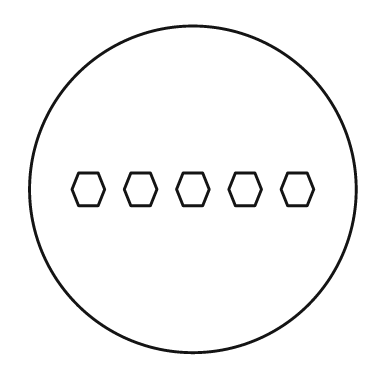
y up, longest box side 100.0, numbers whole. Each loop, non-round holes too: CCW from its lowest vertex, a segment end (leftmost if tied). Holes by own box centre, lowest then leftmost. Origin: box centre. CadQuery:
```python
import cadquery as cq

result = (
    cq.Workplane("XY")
    .moveTo(0.0, 0.0)
    .circle(50.0)
    .moveTo(-35.0, -5.0)
    .lineTo(-29.0, -5.0)
    .lineTo(-27.0, 0.0)
    .lineTo(-29.0, 5.0)
    .lineTo(-35.0, 5.0)
    .lineTo(-37.0, 0.0)
    .close()
    .moveTo(-19.0, -5.0)
    .lineTo(-13.0, -5.0)
    .lineTo(-11.0, 0.0)
    .lineTo(-13.0, 5.0)
    .lineTo(-19.0, 5.0)
    .lineTo(-21.0, 0.0)
    .close()
    .moveTo(-3.0, -5.0)
    .lineTo(3.0, -5.0)
    .lineTo(5.0, 0.0)
    .lineTo(3.0, 5.0)
    .lineTo(-3.0, 5.0)
    .lineTo(-5.0, 0.0)
    .close()
    .moveTo(13.0, -5.0)
    .lineTo(19.0, -5.0)
    .lineTo(21.0, 0.0)
    .lineTo(19.0, 5.0)
    .lineTo(13.0, 5.0)
    .lineTo(11.0, 0.0)
    .close()
    .moveTo(29.0, -5.0)
    .lineTo(35.0, -5.0)
    .lineTo(37.0, 0.0)
    .lineTo(35.0, 5.0)
    .lineTo(29.0, 5.0)
    .lineTo(27.0, 0.0)
    .close()
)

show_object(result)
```